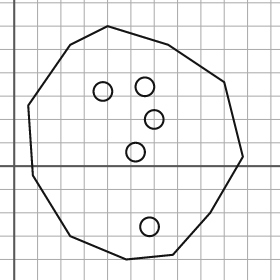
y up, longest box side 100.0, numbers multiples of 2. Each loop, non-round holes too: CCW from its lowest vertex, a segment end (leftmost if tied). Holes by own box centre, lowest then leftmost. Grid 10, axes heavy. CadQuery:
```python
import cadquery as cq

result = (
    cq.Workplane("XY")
    .moveTo(48.0, -40.0)
    .lineTo(68.0, -38.0)
    .lineTo(84.0, -20.0)
    .lineTo(98.0, 4.0)
    .lineTo(90.0, 36.0)
    .lineTo(66.0, 52.0)
    .lineTo(40.0, 60.0)
    .lineTo(24.0, 52.0)
    .lineTo(6.0, 26.0)
    .lineTo(8.0, -4.0)
    .lineTo(24.0, -30.0)
    .close()
    .moveTo(58.0, -26.0)
    .circle(4.0)
    .moveTo(52.0, 6.0)
    .circle(4.0)
    .moveTo(60.0, 20.0)
    .circle(4.0)
    .moveTo(38.0, 32.0)
    .circle(4.0)
    .moveTo(56.0, 34.0)
    .circle(4.0)
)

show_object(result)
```